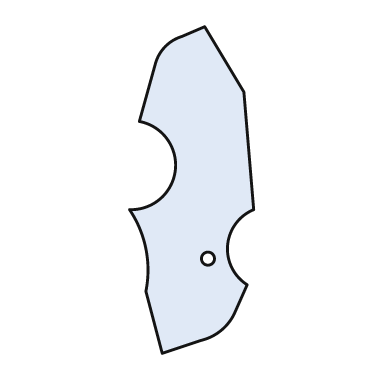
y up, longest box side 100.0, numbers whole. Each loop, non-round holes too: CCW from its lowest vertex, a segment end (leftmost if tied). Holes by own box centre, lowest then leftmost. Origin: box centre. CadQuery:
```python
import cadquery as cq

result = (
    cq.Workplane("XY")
    .moveTo(-9.0, -50.0)
    .lineTo(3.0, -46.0)
    .threePointArc((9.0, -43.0), (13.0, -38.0))
    .lineTo(17.0, -29.0)
    .threePointArc((11.0, -17.0), (19.0, -6.0))
    .lineTo(16.0, 30.0)
    .lineTo(4.0, 50.0)
    .lineTo(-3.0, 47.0)
    .threePointArc((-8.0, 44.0), (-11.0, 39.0))
    .lineTo(-16.0, 21.0)
    .threePointArc((-5.0, 6.0), (-19.0, -6.0))
    .threePointArc((-14.0, -18.0), (-14.0, -31.0))
    .close()
    .moveTo(5.0, -21.0)
    .circle(2.0)
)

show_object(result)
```